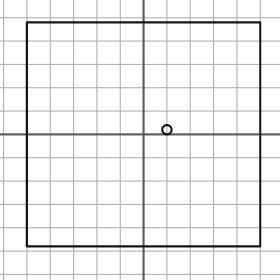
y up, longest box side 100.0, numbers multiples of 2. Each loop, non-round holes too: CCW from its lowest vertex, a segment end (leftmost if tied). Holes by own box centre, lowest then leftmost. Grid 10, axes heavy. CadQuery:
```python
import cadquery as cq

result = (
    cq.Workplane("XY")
    .moveTo(-50.0, -48.0)
    .lineTo(50.0, -48.0)
    .lineTo(50.0, 48.0)
    .lineTo(-50.0, 48.0)
    .close()
    .moveTo(10.0, 2.0)
    .circle(2.0)
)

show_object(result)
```